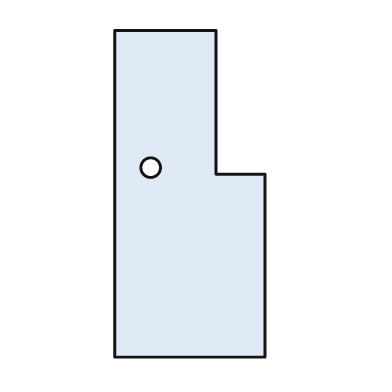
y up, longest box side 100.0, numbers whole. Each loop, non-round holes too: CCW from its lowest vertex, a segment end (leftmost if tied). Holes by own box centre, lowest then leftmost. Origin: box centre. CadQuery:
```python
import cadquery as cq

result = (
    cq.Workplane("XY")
    .moveTo(-23.0, -50.0)
    .lineTo(23.0, -50.0)
    .lineTo(23.0, 6.0)
    .lineTo(8.0, 6.0)
    .lineTo(8.0, 50.0)
    .lineTo(-23.0, 50.0)
    .close()
    .moveTo(-12.0, 8.0)
    .circle(3.0)
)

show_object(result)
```